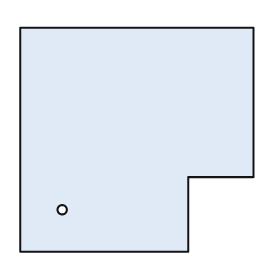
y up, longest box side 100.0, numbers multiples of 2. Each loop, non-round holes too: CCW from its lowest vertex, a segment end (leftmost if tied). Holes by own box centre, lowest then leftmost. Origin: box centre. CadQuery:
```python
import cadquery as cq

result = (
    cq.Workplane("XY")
    .moveTo(-50.0, -48.0)
    .lineTo(22.0, -48.0)
    .lineTo(22.0, -16.0)
    .lineTo(50.0, -16.0)
    .lineTo(50.0, 48.0)
    .lineTo(-50.0, 48.0)
    .close()
    .moveTo(-32.0, -30.0)
    .circle(2.0)
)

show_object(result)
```